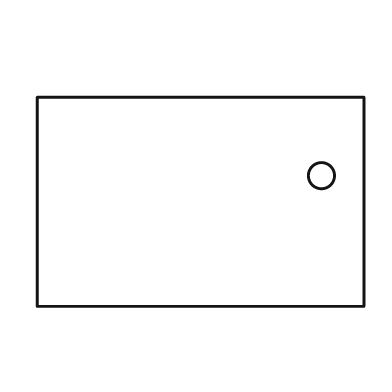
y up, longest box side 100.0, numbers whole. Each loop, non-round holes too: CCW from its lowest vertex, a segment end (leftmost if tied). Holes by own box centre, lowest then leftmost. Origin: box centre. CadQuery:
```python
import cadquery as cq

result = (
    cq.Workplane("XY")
    .moveTo(-50.0, -32.0)
    .lineTo(50.0, -32.0)
    .lineTo(50.0, 32.0)
    .lineTo(-50.0, 32.0)
    .close()
    .moveTo(37.0, 8.0)
    .circle(4.0)
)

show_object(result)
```